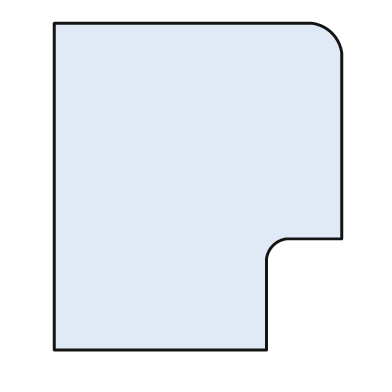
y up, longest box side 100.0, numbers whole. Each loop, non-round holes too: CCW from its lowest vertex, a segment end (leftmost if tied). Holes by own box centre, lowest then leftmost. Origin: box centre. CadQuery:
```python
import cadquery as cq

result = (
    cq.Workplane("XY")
    .moveTo(-44.0, -50.0)
    .lineTo(21.0, -50.0)
    .lineTo(21.0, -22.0)
    .threePointArc((23.0, -18.0), (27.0, -16.0))
    .lineTo(44.0, -16.0)
    .lineTo(44.0, 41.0)
    .threePointArc((41.0, 47.0), (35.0, 50.0))
    .lineTo(-44.0, 50.0)
    .close()
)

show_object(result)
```